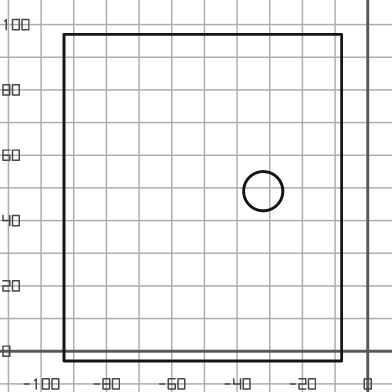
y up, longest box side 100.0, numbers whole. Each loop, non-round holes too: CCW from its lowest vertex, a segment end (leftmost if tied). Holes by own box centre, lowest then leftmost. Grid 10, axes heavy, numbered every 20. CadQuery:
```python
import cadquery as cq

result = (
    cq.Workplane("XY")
    .moveTo(-93.0, -3.0)
    .lineTo(-8.0, -3.0)
    .lineTo(-8.0, 97.0)
    .lineTo(-93.0, 97.0)
    .close()
    .moveTo(-32.0, 49.0)
    .circle(6.0)
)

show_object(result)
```